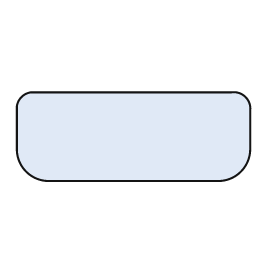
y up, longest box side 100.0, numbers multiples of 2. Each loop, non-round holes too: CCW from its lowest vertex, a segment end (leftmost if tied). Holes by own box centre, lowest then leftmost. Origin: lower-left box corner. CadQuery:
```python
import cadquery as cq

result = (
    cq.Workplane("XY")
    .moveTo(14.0, 0.0)
    .lineTo(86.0, 0.0)
    .threePointArc((96.0, 4.0), (100.0, 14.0))
    .lineTo(100.0, 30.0)
    .threePointArc((98.0, 36.0), (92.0, 38.0))
    .lineTo(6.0, 38.0)
    .threePointArc((2.0, 36.0), (0.0, 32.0))
    .lineTo(0.0, 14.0)
    .threePointArc((4.0, 4.0), (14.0, 0.0))
    .close()
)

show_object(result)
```